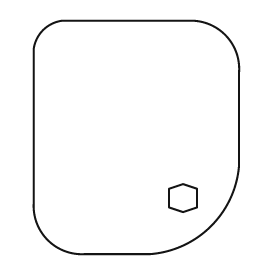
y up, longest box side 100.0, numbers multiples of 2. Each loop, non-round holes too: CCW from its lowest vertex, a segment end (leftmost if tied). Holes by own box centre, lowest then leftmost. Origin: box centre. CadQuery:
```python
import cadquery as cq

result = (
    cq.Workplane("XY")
    .moveTo(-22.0, -50.0)
    .lineTo(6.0, -50.0)
    .threePointArc((32.0, -38.0), (44.0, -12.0))
    .lineTo(44.0, 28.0)
    .threePointArc((38.0, 44.0), (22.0, 50.0))
    .lineTo(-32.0, 50.0)
    .threePointArc((-40.0, 46.0), (-44.0, 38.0))
    .lineTo(-44.0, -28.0)
    .threePointArc((-38.0, -44.0), (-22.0, -50.0))
    .close()
    .moveTo(20.0, -32.0)
    .lineTo(26.0, -30.0)
    .lineTo(26.0, -22.0)
    .lineTo(20.0, -20.0)
    .lineTo(14.0, -22.0)
    .lineTo(14.0, -30.0)
    .close()
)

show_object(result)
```